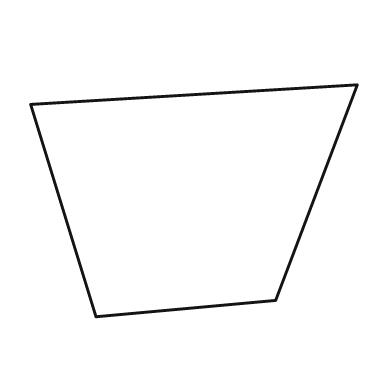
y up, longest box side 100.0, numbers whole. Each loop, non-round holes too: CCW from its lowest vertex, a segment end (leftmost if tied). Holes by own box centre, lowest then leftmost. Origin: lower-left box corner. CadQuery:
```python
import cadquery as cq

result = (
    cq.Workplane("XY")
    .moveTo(20.0, 0.0)
    .lineTo(75.0, 5.0)
    .lineTo(100.0, 71.0)
    .lineTo(0.0, 65.0)
    .close()
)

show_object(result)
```